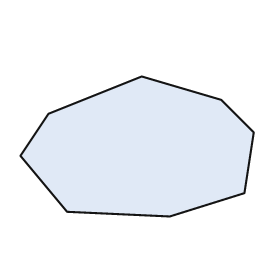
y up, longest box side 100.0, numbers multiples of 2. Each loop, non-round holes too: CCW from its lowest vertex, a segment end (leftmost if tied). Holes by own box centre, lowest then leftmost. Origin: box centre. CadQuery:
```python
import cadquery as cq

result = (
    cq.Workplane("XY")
    .moveTo(14.0, -30.0)
    .lineTo(46.0, -20.0)
    .lineTo(50.0, 6.0)
    .lineTo(36.0, 20.0)
    .lineTo(2.0, 30.0)
    .lineTo(-38.0, 14.0)
    .lineTo(-50.0, -4.0)
    .lineTo(-30.0, -28.0)
    .close()
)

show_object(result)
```